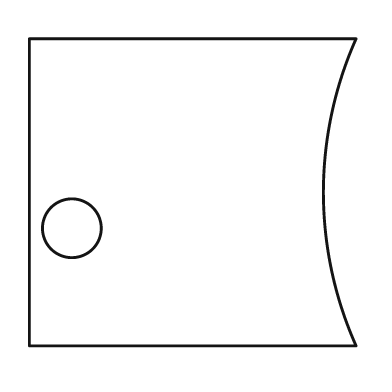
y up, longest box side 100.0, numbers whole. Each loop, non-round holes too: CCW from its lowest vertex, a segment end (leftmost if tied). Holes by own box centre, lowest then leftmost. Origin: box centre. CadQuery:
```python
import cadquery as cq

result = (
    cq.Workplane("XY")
    .moveTo(-50.0, -47.0)
    .lineTo(50.0, -47.0)
    .threePointArc((40.0, 0.0), (50.0, 47.0))
    .lineTo(-50.0, 47.0)
    .close()
    .moveTo(-37.0, -11.0)
    .circle(9.0)
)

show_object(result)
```